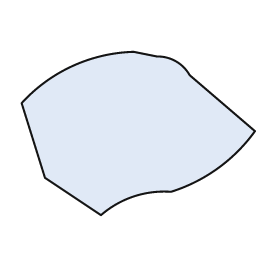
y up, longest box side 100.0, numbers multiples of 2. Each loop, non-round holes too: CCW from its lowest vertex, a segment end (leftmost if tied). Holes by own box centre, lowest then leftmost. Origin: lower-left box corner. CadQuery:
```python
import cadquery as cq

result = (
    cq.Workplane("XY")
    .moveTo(34.0, 0.0)
    .threePointArc((48.0, 8.0), (64.0, 10.0))
    .threePointArc((84.0, 20.0), (100.0, 36.0))
    .lineTo(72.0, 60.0)
    .threePointArc((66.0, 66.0), (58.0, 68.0))
    .lineTo(48.0, 70.0)
    .threePointArc((22.0, 64.0), (0.0, 48.0))
    .lineTo(10.0, 16.0)
    .close()
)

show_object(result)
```